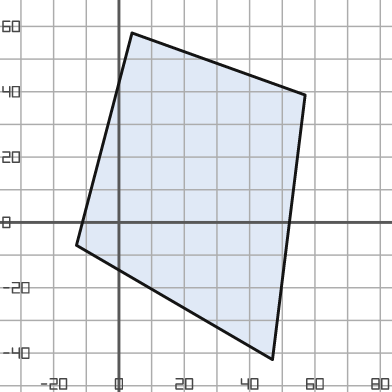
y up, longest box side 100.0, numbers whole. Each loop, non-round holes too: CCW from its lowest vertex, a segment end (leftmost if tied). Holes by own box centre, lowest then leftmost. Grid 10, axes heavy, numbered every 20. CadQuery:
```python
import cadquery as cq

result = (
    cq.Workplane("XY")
    .moveTo(47.0, -42.0)
    .lineTo(57.0, 39.0)
    .lineTo(4.0, 58.0)
    .lineTo(-13.0, -7.0)
    .close()
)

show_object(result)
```